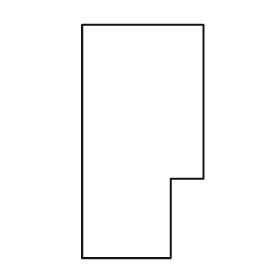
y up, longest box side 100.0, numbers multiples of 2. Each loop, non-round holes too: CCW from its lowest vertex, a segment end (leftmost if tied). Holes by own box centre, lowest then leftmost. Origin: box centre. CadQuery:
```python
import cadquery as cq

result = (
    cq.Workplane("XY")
    .moveTo(-26.0, -50.0)
    .lineTo(12.0, -50.0)
    .lineTo(12.0, -16.0)
    .lineTo(26.0, -16.0)
    .lineTo(26.0, 50.0)
    .lineTo(-26.0, 50.0)
    .close()
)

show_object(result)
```